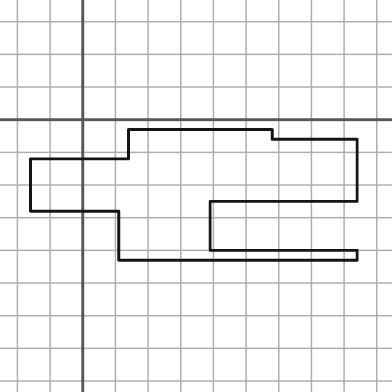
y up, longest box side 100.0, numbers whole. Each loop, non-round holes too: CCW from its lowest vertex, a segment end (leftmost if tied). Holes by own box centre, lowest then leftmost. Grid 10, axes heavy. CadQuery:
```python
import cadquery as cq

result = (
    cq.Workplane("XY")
    .moveTo(11.0, -43.0)
    .lineTo(84.0, -43.0)
    .lineTo(84.0, -40.0)
    .lineTo(39.0, -40.0)
    .lineTo(39.0, -25.0)
    .lineTo(84.0, -25.0)
    .lineTo(84.0, -6.0)
    .lineTo(58.0, -6.0)
    .lineTo(58.0, -3.0)
    .lineTo(14.0, -3.0)
    .lineTo(14.0, -12.0)
    .lineTo(-16.0, -12.0)
    .lineTo(-16.0, -28.0)
    .lineTo(11.0, -28.0)
    .close()
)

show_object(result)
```